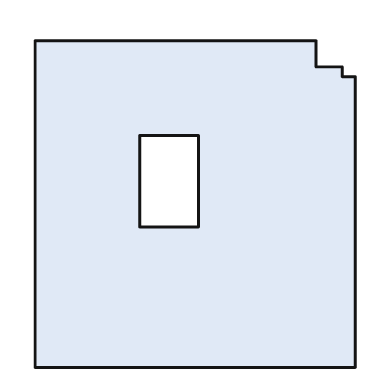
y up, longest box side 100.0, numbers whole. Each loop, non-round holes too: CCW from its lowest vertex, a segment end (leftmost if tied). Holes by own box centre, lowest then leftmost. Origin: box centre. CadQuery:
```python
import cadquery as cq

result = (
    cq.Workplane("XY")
    .moveTo(-49.0, -50.0)
    .lineTo(49.0, -50.0)
    .lineTo(49.0, 39.0)
    .lineTo(45.0, 39.0)
    .lineTo(45.0, 42.0)
    .lineTo(37.0, 42.0)
    .lineTo(37.0, 50.0)
    .lineTo(-49.0, 50.0)
    .close()
    .moveTo(-17.0, -7.0)
    .lineTo(1.0, -7.0)
    .lineTo(1.0, 21.0)
    .lineTo(-17.0, 21.0)
    .close()
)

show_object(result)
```